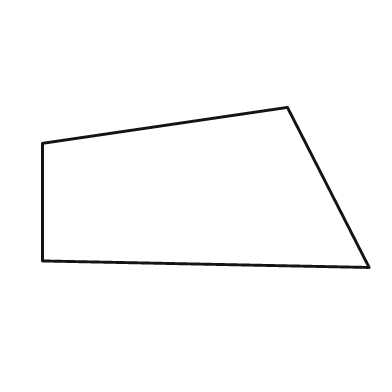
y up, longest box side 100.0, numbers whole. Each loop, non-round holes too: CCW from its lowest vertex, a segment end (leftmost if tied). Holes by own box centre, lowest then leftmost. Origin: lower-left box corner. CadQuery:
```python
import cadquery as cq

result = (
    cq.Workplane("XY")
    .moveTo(100.0, 0.0)
    .lineTo(75.0, 49.0)
    .lineTo(0.0, 38.0)
    .lineTo(0.0, 2.0)
    .close()
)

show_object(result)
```